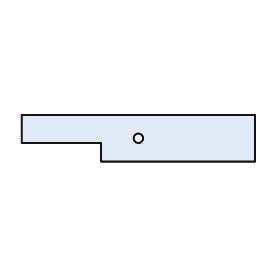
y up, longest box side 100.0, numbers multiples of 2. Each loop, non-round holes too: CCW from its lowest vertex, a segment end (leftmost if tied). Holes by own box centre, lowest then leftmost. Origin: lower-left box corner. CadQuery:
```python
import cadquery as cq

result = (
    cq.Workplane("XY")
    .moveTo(34.0, 0.0)
    .lineTo(100.0, 0.0)
    .lineTo(100.0, 20.0)
    .lineTo(0.0, 20.0)
    .lineTo(0.0, 8.0)
    .lineTo(34.0, 8.0)
    .close()
    .moveTo(50.0, 10.0)
    .circle(2.0)
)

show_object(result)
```